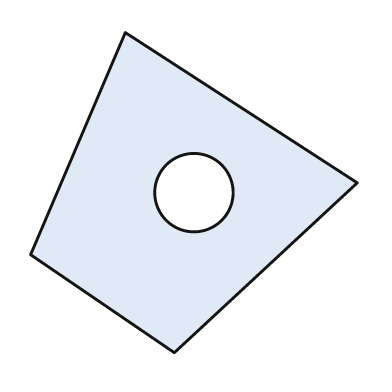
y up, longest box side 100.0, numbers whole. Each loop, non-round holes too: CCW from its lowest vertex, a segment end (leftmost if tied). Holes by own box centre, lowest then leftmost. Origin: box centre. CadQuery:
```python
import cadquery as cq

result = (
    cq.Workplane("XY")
    .moveTo(-6.0, -49.0)
    .lineTo(50.0, 3.0)
    .lineTo(-21.0, 49.0)
    .lineTo(-50.0, -19.0)
    .close()
    .moveTo(0.0, 0.0)
    .circle(12.0)
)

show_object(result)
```